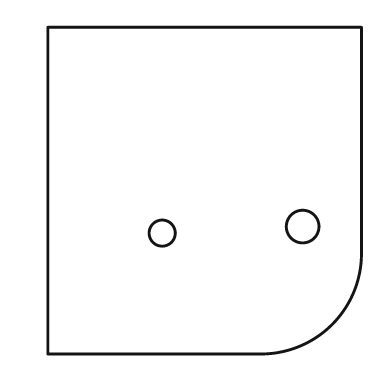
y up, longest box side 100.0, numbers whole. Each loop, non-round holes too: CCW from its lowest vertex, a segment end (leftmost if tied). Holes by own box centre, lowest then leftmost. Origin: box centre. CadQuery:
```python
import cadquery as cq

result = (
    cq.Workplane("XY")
    .moveTo(-48.0, -50.0)
    .lineTo(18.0, -50.0)
    .threePointArc((39.0, -41.0), (48.0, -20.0))
    .lineTo(48.0, 50.0)
    .lineTo(-48.0, 50.0)
    .close()
    .moveTo(-13.0, -13.0)
    .circle(4.0)
    .moveTo(30.0, -11.0)
    .circle(5.0)
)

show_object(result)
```